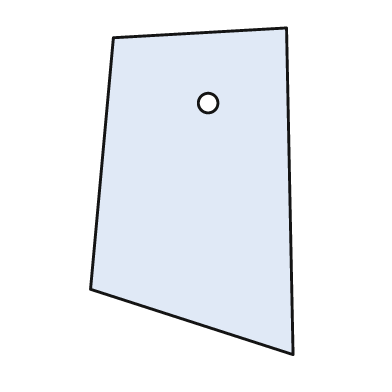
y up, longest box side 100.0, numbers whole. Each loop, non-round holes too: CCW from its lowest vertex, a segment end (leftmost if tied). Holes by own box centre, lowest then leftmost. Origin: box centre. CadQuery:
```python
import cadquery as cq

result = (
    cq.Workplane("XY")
    .moveTo(31.0, -50.0)
    .lineTo(29.0, 50.0)
    .lineTo(-24.0, 47.0)
    .lineTo(-31.0, -30.0)
    .close()
    .moveTo(5.0, 27.0)
    .circle(3.0)
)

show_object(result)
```